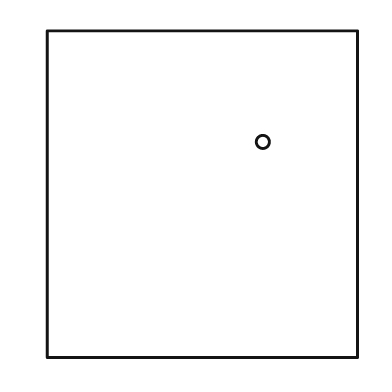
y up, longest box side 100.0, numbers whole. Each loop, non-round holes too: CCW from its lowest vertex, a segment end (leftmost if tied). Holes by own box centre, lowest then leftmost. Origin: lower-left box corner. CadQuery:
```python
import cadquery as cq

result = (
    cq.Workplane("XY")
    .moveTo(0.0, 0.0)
    .lineTo(95.0, 0.0)
    .lineTo(95.0, 100.0)
    .lineTo(0.0, 100.0)
    .close()
    .moveTo(66.0, 66.0)
    .circle(2.0)
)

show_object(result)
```